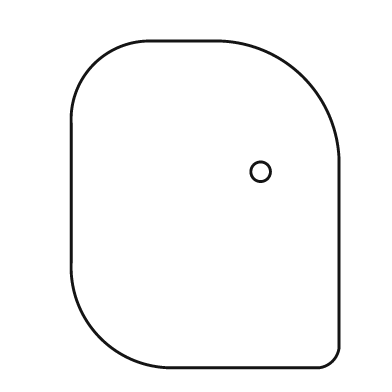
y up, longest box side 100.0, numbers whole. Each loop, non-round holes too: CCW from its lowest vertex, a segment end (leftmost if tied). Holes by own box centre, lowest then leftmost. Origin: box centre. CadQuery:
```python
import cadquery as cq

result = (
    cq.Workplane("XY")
    .moveTo(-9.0, -50.0)
    .lineTo(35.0, -50.0)
    .threePointArc((39.0, -48.0), (41.0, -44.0))
    .lineTo(41.0, 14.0)
    .threePointArc((30.0, 39.0), (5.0, 50.0))
    .lineTo(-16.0, 50.0)
    .threePointArc((-34.0, 43.0), (-41.0, 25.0))
    .lineTo(-41.0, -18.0)
    .threePointArc((-32.0, -41.0), (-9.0, -50.0))
    .close()
    .moveTo(17.0, 10.0)
    .circle(3.0)
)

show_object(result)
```